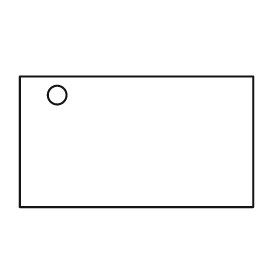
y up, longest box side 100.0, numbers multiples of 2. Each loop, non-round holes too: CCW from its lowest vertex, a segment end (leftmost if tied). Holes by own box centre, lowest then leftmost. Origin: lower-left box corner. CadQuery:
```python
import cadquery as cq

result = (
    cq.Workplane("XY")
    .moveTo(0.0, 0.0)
    .lineTo(100.0, 0.0)
    .lineTo(100.0, 56.0)
    .lineTo(0.0, 56.0)
    .close()
    .moveTo(16.0, 48.0)
    .circle(4.0)
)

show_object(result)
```